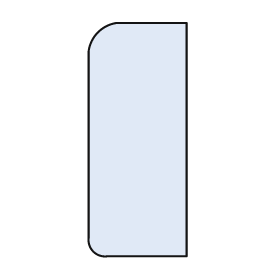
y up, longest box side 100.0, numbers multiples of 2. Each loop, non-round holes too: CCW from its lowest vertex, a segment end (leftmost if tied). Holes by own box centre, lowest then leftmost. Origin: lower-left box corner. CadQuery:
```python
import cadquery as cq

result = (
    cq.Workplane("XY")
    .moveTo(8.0, 0.0)
    .lineTo(42.0, 0.0)
    .lineTo(42.0, 100.0)
    .lineTo(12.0, 100.0)
    .threePointArc((4.0, 96.0), (0.0, 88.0))
    .lineTo(0.0, 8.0)
    .threePointArc((2.0, 2.0), (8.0, 0.0))
    .close()
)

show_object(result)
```